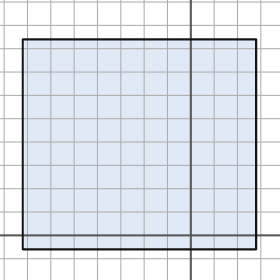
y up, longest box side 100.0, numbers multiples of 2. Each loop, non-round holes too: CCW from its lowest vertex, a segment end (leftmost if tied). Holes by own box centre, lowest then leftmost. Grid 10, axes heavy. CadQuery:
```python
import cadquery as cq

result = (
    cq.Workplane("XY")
    .moveTo(-72.0, -6.0)
    .lineTo(28.0, -6.0)
    .lineTo(28.0, 84.0)
    .lineTo(-72.0, 84.0)
    .close()
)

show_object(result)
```